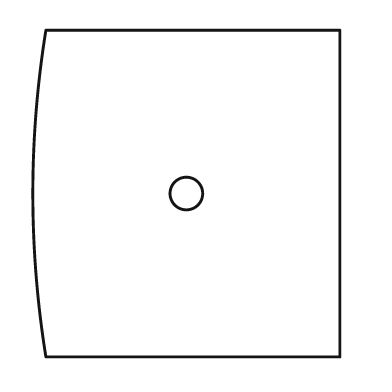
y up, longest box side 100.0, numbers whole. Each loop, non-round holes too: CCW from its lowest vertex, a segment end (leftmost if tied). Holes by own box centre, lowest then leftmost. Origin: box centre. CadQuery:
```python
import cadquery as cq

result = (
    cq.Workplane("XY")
    .moveTo(-43.0, -50.0)
    .lineTo(47.0, -50.0)
    .lineTo(47.0, 50.0)
    .lineTo(-43.0, 50.0)
    .threePointArc((-47.0, 0.0), (-43.0, -50.0))
    .close()
    .moveTo(0.0, 0.0)
    .circle(5.0)
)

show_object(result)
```